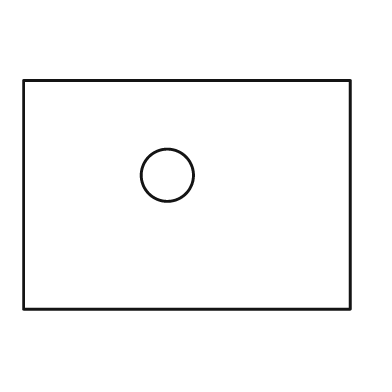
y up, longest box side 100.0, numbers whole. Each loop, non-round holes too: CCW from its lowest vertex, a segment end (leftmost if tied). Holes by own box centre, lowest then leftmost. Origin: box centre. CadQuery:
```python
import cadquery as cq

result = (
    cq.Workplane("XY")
    .moveTo(-50.0, -35.0)
    .lineTo(50.0, -35.0)
    .lineTo(50.0, 35.0)
    .lineTo(-50.0, 35.0)
    .close()
    .moveTo(-6.0, 6.0)
    .circle(8.0)
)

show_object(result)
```